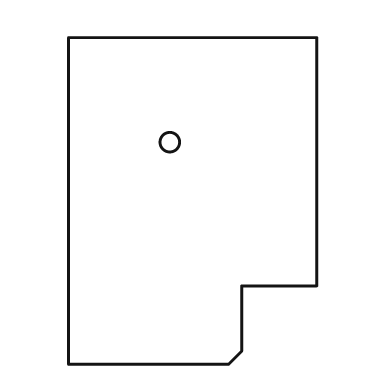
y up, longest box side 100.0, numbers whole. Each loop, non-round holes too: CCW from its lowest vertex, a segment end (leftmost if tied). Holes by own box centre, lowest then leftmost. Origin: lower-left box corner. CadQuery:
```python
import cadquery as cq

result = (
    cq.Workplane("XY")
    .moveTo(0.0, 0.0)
    .lineTo(49.0, 0.0)
    .lineTo(53.0, 4.0)
    .lineTo(53.0, 24.0)
    .lineTo(76.0, 24.0)
    .lineTo(76.0, 100.0)
    .lineTo(0.0, 100.0)
    .close()
    .moveTo(31.0, 68.0)
    .circle(3.0)
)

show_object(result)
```